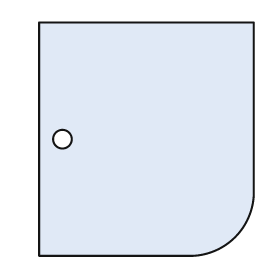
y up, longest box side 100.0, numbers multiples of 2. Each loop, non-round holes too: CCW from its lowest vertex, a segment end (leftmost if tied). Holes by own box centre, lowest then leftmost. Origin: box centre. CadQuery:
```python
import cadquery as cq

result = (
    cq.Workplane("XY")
    .moveTo(-46.0, -50.0)
    .lineTo(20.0, -50.0)
    .threePointArc((38.0, -42.0), (46.0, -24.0))
    .lineTo(46.0, 50.0)
    .lineTo(-46.0, 50.0)
    .close()
    .moveTo(-36.0, 0.0)
    .circle(4.0)
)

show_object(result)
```